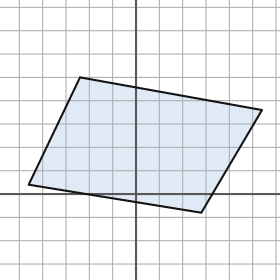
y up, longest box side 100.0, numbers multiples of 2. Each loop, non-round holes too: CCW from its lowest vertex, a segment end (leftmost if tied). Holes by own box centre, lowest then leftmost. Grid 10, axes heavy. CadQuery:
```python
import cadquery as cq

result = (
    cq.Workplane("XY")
    .moveTo(28.0, -8.0)
    .lineTo(54.0, 36.0)
    .lineTo(-24.0, 50.0)
    .lineTo(-46.0, 4.0)
    .close()
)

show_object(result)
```